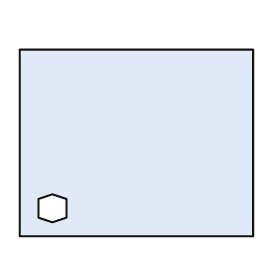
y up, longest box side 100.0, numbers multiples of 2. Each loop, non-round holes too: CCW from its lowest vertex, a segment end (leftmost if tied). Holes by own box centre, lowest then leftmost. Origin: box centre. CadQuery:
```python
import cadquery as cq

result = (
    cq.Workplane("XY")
    .moveTo(-50.0, -40.0)
    .lineTo(50.0, -40.0)
    .lineTo(50.0, 40.0)
    .lineTo(-50.0, 40.0)
    .close()
    .moveTo(-36.0, -34.0)
    .lineTo(-30.0, -32.0)
    .lineTo(-30.0, -24.0)
    .lineTo(-36.0, -22.0)
    .lineTo(-42.0, -24.0)
    .lineTo(-42.0, -32.0)
    .close()
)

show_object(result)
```